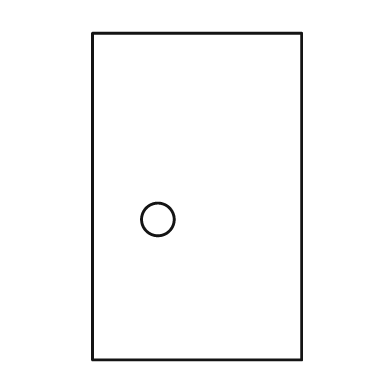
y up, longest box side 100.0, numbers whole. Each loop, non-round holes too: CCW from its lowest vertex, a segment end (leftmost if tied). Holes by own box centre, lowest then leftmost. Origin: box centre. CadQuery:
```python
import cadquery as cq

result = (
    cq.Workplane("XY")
    .moveTo(-32.0, -50.0)
    .lineTo(32.0, -50.0)
    .lineTo(32.0, 50.0)
    .lineTo(-32.0, 50.0)
    .close()
    .moveTo(-12.0, -7.0)
    .circle(5.0)
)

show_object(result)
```